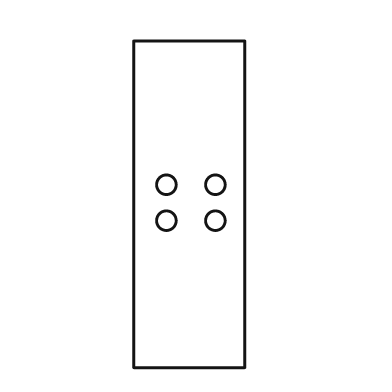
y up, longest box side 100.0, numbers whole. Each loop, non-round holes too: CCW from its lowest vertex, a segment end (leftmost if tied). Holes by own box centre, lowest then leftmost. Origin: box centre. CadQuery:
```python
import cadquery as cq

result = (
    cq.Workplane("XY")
    .moveTo(-17.0, -50.0)
    .lineTo(17.0, -50.0)
    .lineTo(17.0, 50.0)
    .lineTo(-17.0, 50.0)
    .close()
    .moveTo(-7.0, -5.0)
    .circle(3.0)
    .moveTo(8.0, -5.0)
    .circle(3.0)
    .moveTo(-7.0, 6.0)
    .circle(3.0)
    .moveTo(8.0, 6.0)
    .circle(3.0)
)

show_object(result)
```